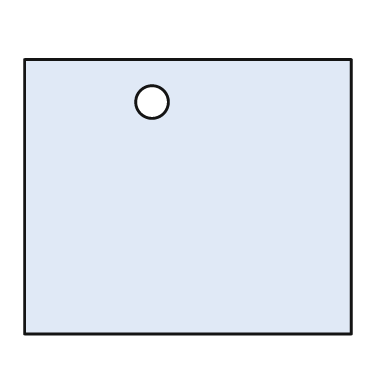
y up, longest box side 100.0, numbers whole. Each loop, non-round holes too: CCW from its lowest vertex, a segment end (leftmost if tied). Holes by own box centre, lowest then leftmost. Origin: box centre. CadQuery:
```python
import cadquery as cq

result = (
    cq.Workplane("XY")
    .moveTo(-50.0, -42.0)
    .lineTo(50.0, -42.0)
    .lineTo(50.0, 42.0)
    .lineTo(-50.0, 42.0)
    .close()
    .moveTo(-11.0, 29.0)
    .circle(5.0)
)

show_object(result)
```